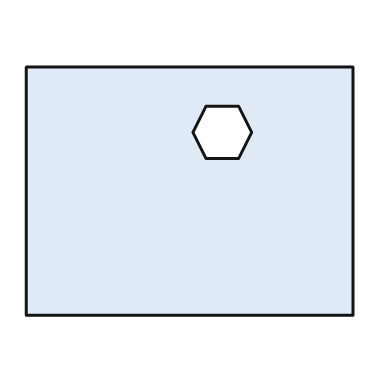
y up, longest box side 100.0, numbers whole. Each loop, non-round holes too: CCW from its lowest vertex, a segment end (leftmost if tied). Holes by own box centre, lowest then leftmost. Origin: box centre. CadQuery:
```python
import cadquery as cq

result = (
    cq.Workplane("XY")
    .moveTo(-50.0, -38.0)
    .lineTo(50.0, -38.0)
    .lineTo(50.0, 38.0)
    .lineTo(-50.0, 38.0)
    .close()
    .moveTo(5.0, 10.0)
    .lineTo(15.0, 10.0)
    .lineTo(19.0, 18.0)
    .lineTo(15.0, 26.0)
    .lineTo(5.0, 26.0)
    .lineTo(1.0, 18.0)
    .close()
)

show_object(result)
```